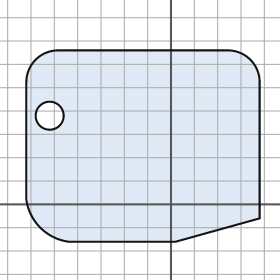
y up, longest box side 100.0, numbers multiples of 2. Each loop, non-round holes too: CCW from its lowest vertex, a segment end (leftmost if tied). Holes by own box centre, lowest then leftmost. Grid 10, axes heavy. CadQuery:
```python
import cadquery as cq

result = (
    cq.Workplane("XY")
    .moveTo(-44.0, -16.0)
    .lineTo(2.0, -16.0)
    .lineTo(38.0, -6.0)
    .lineTo(38.0, 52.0)
    .threePointArc((34.0, 62.0), (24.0, 66.0))
    .lineTo(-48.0, 66.0)
    .threePointArc((-58.0, 62.0), (-62.0, 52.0))
    .lineTo(-62.0, 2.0)
    .threePointArc((-56.0, -10.0), (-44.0, -16.0))
    .close()
    .moveTo(-52.0, 38.0)
    .circle(6.0)
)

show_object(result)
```